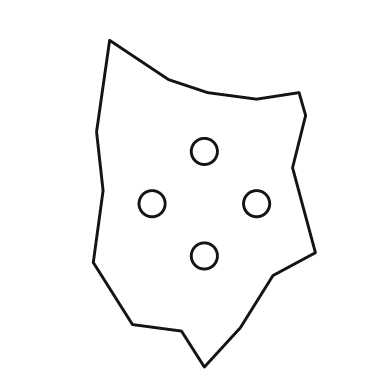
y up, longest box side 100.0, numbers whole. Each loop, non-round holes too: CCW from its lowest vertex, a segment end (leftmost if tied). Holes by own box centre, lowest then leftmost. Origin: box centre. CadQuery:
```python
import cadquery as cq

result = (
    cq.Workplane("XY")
    .moveTo(0.0, -50.0)
    .lineTo(11.0, -38.0)
    .lineTo(21.0, -22.0)
    .lineTo(34.0, -15.0)
    .lineTo(27.0, 11.0)
    .lineTo(31.0, 27.0)
    .lineTo(29.0, 34.0)
    .lineTo(16.0, 32.0)
    .lineTo(1.0, 34.0)
    .lineTo(-11.0, 38.0)
    .lineTo(-29.0, 50.0)
    .lineTo(-33.0, 22.0)
    .lineTo(-31.0, 4.0)
    .lineTo(-34.0, -18.0)
    .lineTo(-22.0, -37.0)
    .lineTo(-7.0, -39.0)
    .close()
    .moveTo(0.0, -16.0)
    .circle(4.0)
    .moveTo(-16.0, 0.0)
    .circle(4.0)
    .moveTo(16.0, 0.0)
    .circle(4.0)
    .moveTo(0.0, 16.0)
    .circle(4.0)
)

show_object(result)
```